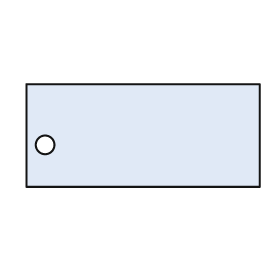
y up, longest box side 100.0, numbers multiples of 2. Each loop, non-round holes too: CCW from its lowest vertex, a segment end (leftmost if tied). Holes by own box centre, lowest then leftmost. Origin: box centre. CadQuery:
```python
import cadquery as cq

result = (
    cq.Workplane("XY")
    .moveTo(-50.0, -22.0)
    .lineTo(50.0, -22.0)
    .lineTo(50.0, 22.0)
    .lineTo(-50.0, 22.0)
    .close()
    .moveTo(-42.0, -4.0)
    .circle(4.0)
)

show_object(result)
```